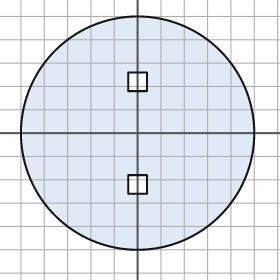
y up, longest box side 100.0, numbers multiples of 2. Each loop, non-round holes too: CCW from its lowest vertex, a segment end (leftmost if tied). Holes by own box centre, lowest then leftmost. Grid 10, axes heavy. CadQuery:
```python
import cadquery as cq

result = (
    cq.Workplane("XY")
    .moveTo(0.0, 0.0)
    .circle(50.0)
    .moveTo(-4.0, -26.0)
    .lineTo(4.0, -26.0)
    .lineTo(4.0, -18.0)
    .lineTo(-4.0, -18.0)
    .close()
    .moveTo(-4.0, 18.0)
    .lineTo(4.0, 18.0)
    .lineTo(4.0, 26.0)
    .lineTo(-4.0, 26.0)
    .close()
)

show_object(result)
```